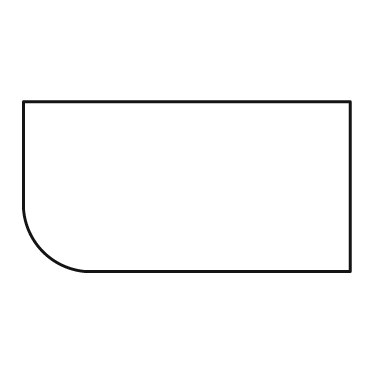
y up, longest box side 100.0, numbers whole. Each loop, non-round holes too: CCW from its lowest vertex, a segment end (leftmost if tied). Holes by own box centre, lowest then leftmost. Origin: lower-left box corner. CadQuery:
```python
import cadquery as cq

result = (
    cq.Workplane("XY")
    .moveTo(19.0, 0.0)
    .lineTo(100.0, 0.0)
    .lineTo(100.0, 52.0)
    .lineTo(0.0, 52.0)
    .lineTo(0.0, 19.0)
    .threePointArc((6.0, 6.0), (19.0, 0.0))
    .close()
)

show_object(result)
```